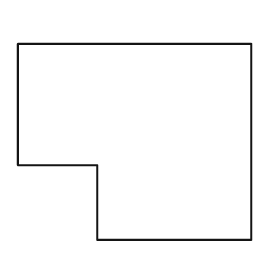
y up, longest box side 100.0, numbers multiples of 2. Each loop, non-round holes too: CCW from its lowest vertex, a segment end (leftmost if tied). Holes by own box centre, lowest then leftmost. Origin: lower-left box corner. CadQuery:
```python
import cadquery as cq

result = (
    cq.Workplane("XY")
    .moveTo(34.0, 0.0)
    .lineTo(100.0, 0.0)
    .lineTo(100.0, 84.0)
    .lineTo(0.0, 84.0)
    .lineTo(0.0, 32.0)
    .lineTo(34.0, 32.0)
    .close()
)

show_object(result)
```